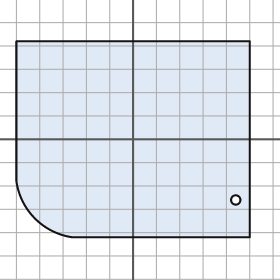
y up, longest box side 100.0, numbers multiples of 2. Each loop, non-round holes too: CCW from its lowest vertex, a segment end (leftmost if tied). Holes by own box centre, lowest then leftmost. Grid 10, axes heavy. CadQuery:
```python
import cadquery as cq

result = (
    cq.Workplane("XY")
    .moveTo(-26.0, -42.0)
    .lineTo(50.0, -42.0)
    .lineTo(50.0, 42.0)
    .lineTo(-50.0, 42.0)
    .lineTo(-50.0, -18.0)
    .threePointArc((-42.0, -34.0), (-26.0, -42.0))
    .close()
    .moveTo(44.0, -26.0)
    .circle(2.0)
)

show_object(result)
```